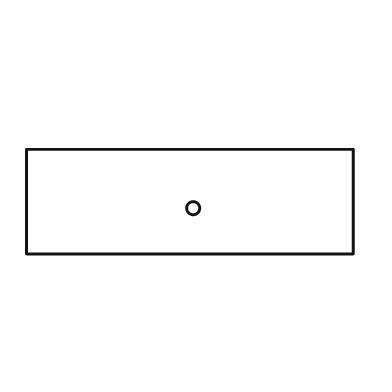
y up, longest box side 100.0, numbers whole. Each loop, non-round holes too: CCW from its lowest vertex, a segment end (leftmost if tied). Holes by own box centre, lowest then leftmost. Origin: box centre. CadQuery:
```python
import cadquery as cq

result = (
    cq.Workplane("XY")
    .moveTo(-50.0, -16.0)
    .lineTo(50.0, -16.0)
    .lineTo(50.0, 16.0)
    .lineTo(-50.0, 16.0)
    .close()
    .moveTo(1.0, -2.0)
    .circle(2.0)
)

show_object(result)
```